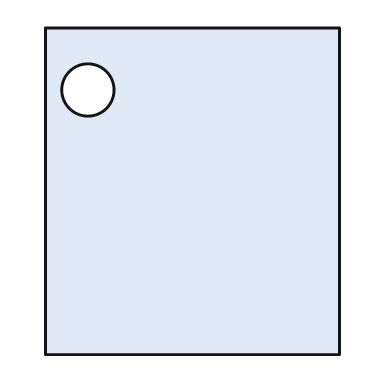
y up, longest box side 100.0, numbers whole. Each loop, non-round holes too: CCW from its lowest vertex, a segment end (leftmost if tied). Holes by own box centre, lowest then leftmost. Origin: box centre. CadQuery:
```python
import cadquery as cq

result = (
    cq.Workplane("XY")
    .moveTo(-45.0, -50.0)
    .lineTo(45.0, -50.0)
    .lineTo(45.0, 50.0)
    .lineTo(-45.0, 50.0)
    .close()
    .moveTo(-32.0, 31.0)
    .circle(8.0)
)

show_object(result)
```